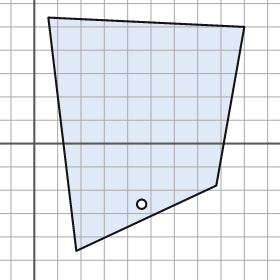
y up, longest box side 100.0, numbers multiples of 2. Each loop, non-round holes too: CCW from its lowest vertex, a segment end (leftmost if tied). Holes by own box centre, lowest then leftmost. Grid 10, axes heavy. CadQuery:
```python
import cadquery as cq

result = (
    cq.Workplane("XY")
    .moveTo(18.0, -46.0)
    .lineTo(78.0, -18.0)
    .lineTo(90.0, 50.0)
    .lineTo(6.0, 54.0)
    .close()
    .moveTo(46.0, -26.0)
    .circle(2.0)
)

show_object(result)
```